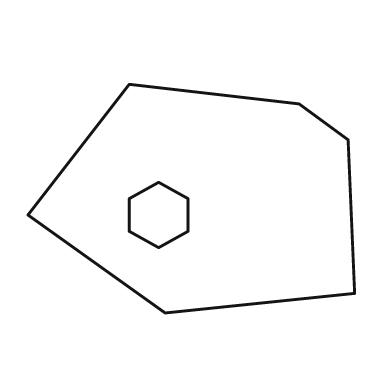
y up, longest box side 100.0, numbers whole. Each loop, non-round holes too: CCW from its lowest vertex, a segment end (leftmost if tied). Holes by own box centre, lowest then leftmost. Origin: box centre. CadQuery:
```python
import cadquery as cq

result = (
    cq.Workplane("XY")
    .moveTo(-8.0, -35.0)
    .lineTo(50.0, -29.0)
    .lineTo(48.0, 18.0)
    .lineTo(33.0, 29.0)
    .lineTo(-19.0, 35.0)
    .lineTo(-50.0, -5.0)
    .close()
    .moveTo(-10.0, -15.0)
    .lineTo(-1.0, -10.0)
    .lineTo(-1.0, 0.0)
    .lineTo(-10.0, 5.0)
    .lineTo(-19.0, 0.0)
    .lineTo(-19.0, -10.0)
    .close()
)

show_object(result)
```